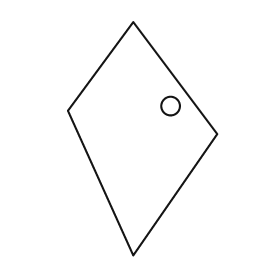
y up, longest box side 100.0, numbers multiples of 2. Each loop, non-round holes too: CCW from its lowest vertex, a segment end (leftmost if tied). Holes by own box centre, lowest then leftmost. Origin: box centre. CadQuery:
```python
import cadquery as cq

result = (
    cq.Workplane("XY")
    .moveTo(-4.0, -50.0)
    .lineTo(32.0, 2.0)
    .lineTo(-4.0, 50.0)
    .lineTo(-32.0, 12.0)
    .close()
    .moveTo(12.0, 14.0)
    .circle(4.0)
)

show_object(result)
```